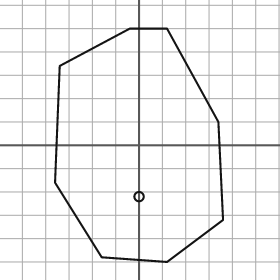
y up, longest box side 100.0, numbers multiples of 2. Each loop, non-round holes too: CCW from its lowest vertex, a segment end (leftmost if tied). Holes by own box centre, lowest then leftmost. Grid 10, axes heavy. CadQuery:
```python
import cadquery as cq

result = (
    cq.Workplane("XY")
    .moveTo(12.0, -50.0)
    .lineTo(36.0, -32.0)
    .lineTo(34.0, 10.0)
    .lineTo(12.0, 50.0)
    .lineTo(-4.0, 50.0)
    .lineTo(-34.0, 34.0)
    .lineTo(-36.0, -16.0)
    .lineTo(-16.0, -48.0)
    .close()
    .moveTo(0.0, -22.0)
    .circle(2.0)
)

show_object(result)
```